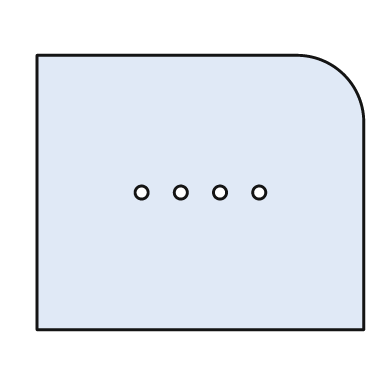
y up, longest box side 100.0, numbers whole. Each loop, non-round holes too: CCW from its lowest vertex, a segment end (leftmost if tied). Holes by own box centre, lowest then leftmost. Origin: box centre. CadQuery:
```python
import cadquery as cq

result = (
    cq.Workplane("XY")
    .moveTo(-50.0, -42.0)
    .lineTo(50.0, -42.0)
    .lineTo(50.0, 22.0)
    .threePointArc((44.0, 36.0), (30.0, 42.0))
    .lineTo(-50.0, 42.0)
    .close()
    .moveTo(-18.0, 0.0)
    .circle(2.0)
    .moveTo(-6.0, 0.0)
    .circle(2.0)
    .moveTo(6.0, 0.0)
    .circle(2.0)
    .moveTo(18.0, 0.0)
    .circle(2.0)
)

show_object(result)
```